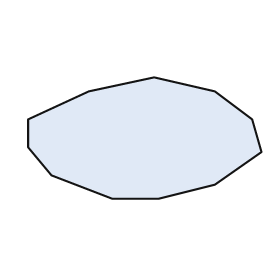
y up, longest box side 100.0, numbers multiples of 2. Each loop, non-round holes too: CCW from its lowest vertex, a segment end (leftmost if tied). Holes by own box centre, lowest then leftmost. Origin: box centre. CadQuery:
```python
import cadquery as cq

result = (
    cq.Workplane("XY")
    .moveTo(-14.0, -26.0)
    .lineTo(6.0, -26.0)
    .lineTo(30.0, -20.0)
    .lineTo(50.0, -6.0)
    .lineTo(46.0, 8.0)
    .lineTo(30.0, 20.0)
    .lineTo(4.0, 26.0)
    .lineTo(-24.0, 20.0)
    .lineTo(-50.0, 8.0)
    .lineTo(-50.0, -4.0)
    .lineTo(-40.0, -16.0)
    .close()
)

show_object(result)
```